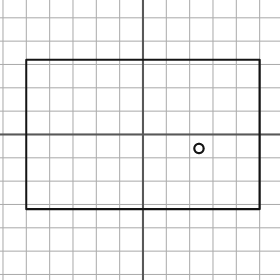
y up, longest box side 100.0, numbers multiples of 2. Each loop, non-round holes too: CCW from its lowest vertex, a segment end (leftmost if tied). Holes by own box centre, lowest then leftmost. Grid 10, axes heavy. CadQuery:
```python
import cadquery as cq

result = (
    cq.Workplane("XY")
    .moveTo(-50.0, -32.0)
    .lineTo(50.0, -32.0)
    .lineTo(50.0, 32.0)
    .lineTo(-50.0, 32.0)
    .close()
    .moveTo(24.0, -6.0)
    .circle(2.0)
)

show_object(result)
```